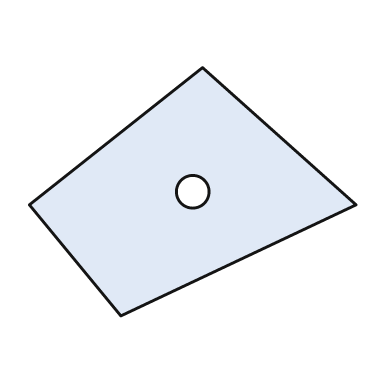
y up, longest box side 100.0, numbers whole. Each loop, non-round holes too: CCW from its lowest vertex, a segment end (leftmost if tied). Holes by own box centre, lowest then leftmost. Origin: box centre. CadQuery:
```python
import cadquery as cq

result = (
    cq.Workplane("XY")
    .moveTo(-22.0, -38.0)
    .lineTo(50.0, -4.0)
    .lineTo(3.0, 38.0)
    .lineTo(-50.0, -4.0)
    .close()
    .moveTo(0.0, 0.0)
    .circle(5.0)
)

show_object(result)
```